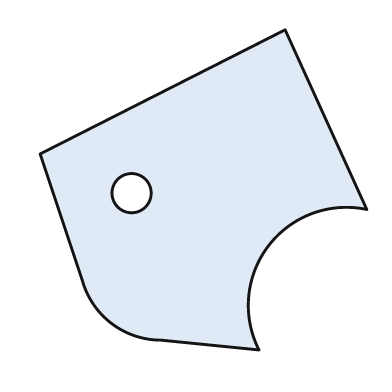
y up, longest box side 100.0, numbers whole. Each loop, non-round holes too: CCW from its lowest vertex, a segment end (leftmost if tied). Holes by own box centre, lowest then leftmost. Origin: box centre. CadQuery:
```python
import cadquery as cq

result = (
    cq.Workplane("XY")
    .moveTo(17.0, -49.0)
    .threePointArc((20.0, -17.0), (50.0, -6.0))
    .lineTo(25.0, 49.0)
    .lineTo(-50.0, 11.0)
    .lineTo(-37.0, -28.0)
    .threePointArc((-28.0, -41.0), (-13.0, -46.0))
    .close()
    .moveTo(-22.0, -1.0)
    .circle(6.0)
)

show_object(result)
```